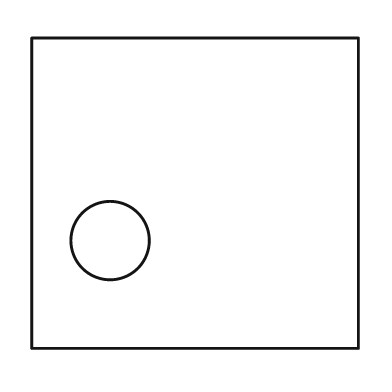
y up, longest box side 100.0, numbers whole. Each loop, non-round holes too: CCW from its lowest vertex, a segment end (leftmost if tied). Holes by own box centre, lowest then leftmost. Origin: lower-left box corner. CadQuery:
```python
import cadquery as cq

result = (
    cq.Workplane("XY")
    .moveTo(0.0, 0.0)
    .lineTo(100.0, 0.0)
    .lineTo(100.0, 95.0)
    .lineTo(0.0, 95.0)
    .close()
    .moveTo(24.0, 33.0)
    .circle(12.0)
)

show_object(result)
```